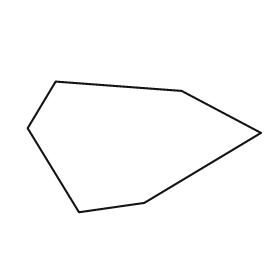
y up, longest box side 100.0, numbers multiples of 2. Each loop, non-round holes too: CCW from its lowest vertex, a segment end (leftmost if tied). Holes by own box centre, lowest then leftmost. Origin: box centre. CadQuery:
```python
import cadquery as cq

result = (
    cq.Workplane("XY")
    .moveTo(-28.0, -28.0)
    .lineTo(0.0, -24.0)
    .lineTo(50.0, 6.0)
    .lineTo(16.0, 24.0)
    .lineTo(-38.0, 28.0)
    .lineTo(-50.0, 8.0)
    .close()
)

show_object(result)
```